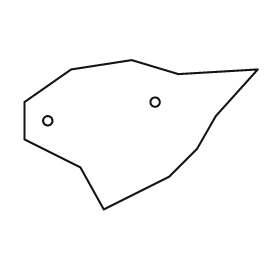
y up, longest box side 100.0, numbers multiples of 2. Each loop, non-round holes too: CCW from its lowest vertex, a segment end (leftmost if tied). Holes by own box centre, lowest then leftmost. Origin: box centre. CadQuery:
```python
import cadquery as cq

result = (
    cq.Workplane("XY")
    .moveTo(-16.0, -32.0)
    .lineTo(12.0, -18.0)
    .lineTo(24.0, -6.0)
    .lineTo(32.0, 8.0)
    .lineTo(50.0, 28.0)
    .lineTo(16.0, 26.0)
    .lineTo(-4.0, 32.0)
    .lineTo(-30.0, 28.0)
    .lineTo(-50.0, 14.0)
    .lineTo(-50.0, -2.0)
    .lineTo(-26.0, -14.0)
    .close()
    .moveTo(-40.0, 6.0)
    .circle(2.0)
    .moveTo(6.0, 14.0)
    .circle(2.0)
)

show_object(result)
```